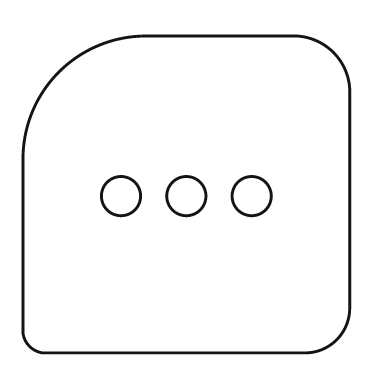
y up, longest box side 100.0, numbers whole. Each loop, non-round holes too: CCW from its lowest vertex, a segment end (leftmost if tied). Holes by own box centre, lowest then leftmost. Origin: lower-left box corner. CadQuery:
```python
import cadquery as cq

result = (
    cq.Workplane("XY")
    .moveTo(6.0, 0.0)
    .lineTo(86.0, 0.0)
    .threePointArc((96.0, 4.0), (100.0, 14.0))
    .lineTo(100.0, 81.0)
    .threePointArc((95.0, 92.0), (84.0, 97.0))
    .lineTo(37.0, 97.0)
    .threePointArc((11.0, 86.0), (0.0, 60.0))
    .lineTo(0.0, 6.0)
    .threePointArc((2.0, 2.0), (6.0, 0.0))
    .close()
    .moveTo(30.0, 48.0)
    .circle(6.0)
    .moveTo(50.0, 48.0)
    .circle(6.0)
    .moveTo(70.0, 48.0)
    .circle(6.0)
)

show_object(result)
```